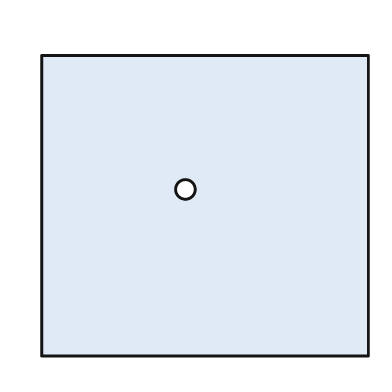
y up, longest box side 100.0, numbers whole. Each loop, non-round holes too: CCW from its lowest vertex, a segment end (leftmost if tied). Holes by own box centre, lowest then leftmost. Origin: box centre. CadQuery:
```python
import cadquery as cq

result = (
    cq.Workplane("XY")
    .moveTo(-50.0, -46.0)
    .lineTo(50.0, -46.0)
    .lineTo(50.0, 46.0)
    .lineTo(-50.0, 46.0)
    .close()
    .moveTo(-6.0, 5.0)
    .circle(3.0)
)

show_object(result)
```